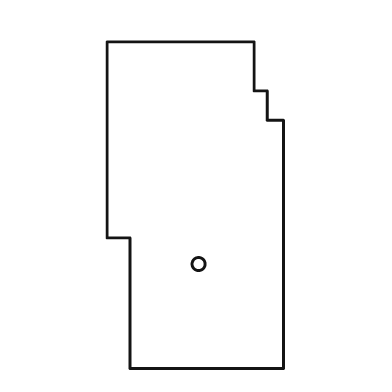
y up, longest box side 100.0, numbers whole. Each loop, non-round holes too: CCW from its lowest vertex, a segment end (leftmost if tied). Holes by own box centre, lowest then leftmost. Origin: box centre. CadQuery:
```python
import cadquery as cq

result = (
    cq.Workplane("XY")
    .moveTo(-20.0, -50.0)
    .lineTo(27.0, -50.0)
    .lineTo(27.0, 26.0)
    .lineTo(22.0, 26.0)
    .lineTo(22.0, 35.0)
    .lineTo(18.0, 35.0)
    .lineTo(18.0, 50.0)
    .lineTo(-27.0, 50.0)
    .lineTo(-27.0, -10.0)
    .lineTo(-20.0, -10.0)
    .close()
    .moveTo(1.0, -18.0)
    .circle(2.0)
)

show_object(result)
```